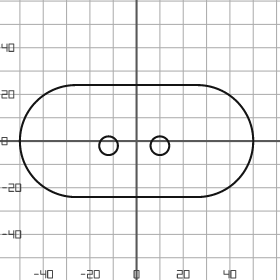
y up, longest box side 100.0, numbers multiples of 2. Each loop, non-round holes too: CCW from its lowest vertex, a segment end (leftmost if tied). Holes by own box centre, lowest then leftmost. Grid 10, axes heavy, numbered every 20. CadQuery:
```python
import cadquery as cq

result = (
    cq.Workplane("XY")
    .moveTo(-26.0, -24.0)
    .lineTo(26.0, -24.0)
    .threePointArc((50.0, 0.0), (26.0, 24.0))
    .lineTo(-26.0, 24.0)
    .threePointArc((-50.0, 0.0), (-26.0, -24.0))
    .close()
    .moveTo(-12.0, -2.0)
    .circle(4.0)
    .moveTo(10.0, -2.0)
    .circle(4.0)
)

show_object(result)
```